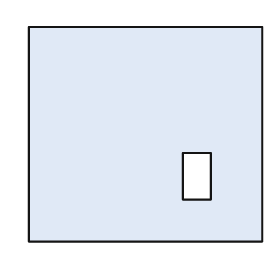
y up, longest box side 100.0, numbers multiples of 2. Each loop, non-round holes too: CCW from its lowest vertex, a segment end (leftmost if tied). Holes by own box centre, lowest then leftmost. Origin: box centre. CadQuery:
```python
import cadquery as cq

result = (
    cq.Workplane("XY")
    .moveTo(-50.0, -46.0)
    .lineTo(50.0, -46.0)
    .lineTo(50.0, 46.0)
    .lineTo(-50.0, 46.0)
    .close()
    .moveTo(16.0, -28.0)
    .lineTo(28.0, -28.0)
    .lineTo(28.0, -8.0)
    .lineTo(16.0, -8.0)
    .close()
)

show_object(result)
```